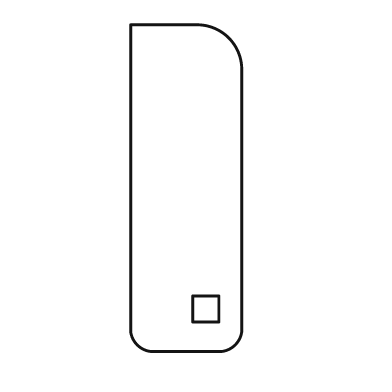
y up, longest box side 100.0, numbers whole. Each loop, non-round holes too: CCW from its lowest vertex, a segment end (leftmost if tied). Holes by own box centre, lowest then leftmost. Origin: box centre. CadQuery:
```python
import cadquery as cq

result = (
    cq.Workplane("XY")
    .moveTo(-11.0, -50.0)
    .lineTo(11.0, -50.0)
    .threePointArc((15.0, -48.0), (17.0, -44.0))
    .lineTo(17.0, 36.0)
    .threePointArc((13.0, 46.0), (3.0, 50.0))
    .lineTo(-17.0, 50.0)
    .lineTo(-17.0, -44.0)
    .threePointArc((-15.0, -48.0), (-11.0, -50.0))
    .close()
    .moveTo(2.0, -41.0)
    .lineTo(10.0, -41.0)
    .lineTo(10.0, -33.0)
    .lineTo(2.0, -33.0)
    .close()
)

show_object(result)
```